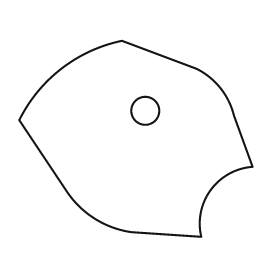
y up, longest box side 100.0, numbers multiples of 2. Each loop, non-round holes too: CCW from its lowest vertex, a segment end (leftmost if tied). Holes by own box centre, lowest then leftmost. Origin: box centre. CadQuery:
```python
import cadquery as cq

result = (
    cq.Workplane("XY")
    .moveTo(28.0, -42.0)
    .threePointArc((32.0, -22.0), (50.0, -12.0))
    .lineTo(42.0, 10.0)
    .threePointArc((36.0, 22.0), (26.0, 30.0))
    .lineTo(-6.0, 42.0)
    .threePointArc((-32.0, 30.0), (-50.0, 8.0))
    .lineTo(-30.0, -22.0)
    .threePointArc((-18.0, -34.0), (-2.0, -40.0))
    .close()
    .moveTo(4.0, 12.0)
    .circle(6.0)
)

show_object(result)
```